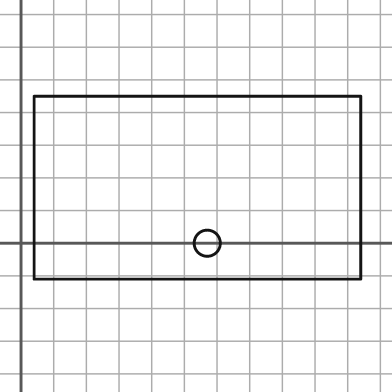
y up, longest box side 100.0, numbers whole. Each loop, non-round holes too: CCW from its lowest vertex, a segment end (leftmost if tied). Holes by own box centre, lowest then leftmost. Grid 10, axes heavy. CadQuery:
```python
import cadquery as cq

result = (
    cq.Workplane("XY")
    .moveTo(4.0, -11.0)
    .lineTo(104.0, -11.0)
    .lineTo(104.0, 45.0)
    .lineTo(4.0, 45.0)
    .close()
    .moveTo(57.0, 0.0)
    .circle(4.0)
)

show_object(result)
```